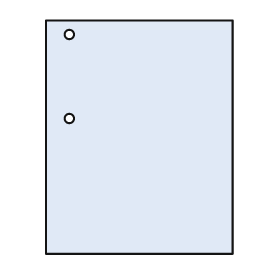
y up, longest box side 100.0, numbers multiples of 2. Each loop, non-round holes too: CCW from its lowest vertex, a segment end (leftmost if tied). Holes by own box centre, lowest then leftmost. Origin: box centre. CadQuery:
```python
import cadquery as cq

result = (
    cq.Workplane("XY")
    .moveTo(-40.0, -50.0)
    .lineTo(40.0, -50.0)
    .lineTo(40.0, 50.0)
    .lineTo(-40.0, 50.0)
    .close()
    .moveTo(-30.0, 8.0)
    .circle(2.0)
    .moveTo(-30.0, 44.0)
    .circle(2.0)
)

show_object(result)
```